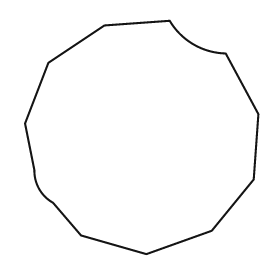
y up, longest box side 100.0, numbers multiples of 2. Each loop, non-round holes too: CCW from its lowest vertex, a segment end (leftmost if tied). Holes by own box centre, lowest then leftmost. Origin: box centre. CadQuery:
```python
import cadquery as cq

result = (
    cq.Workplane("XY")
    .moveTo(2.0, -50.0)
    .lineTo(30.0, -40.0)
    .lineTo(48.0, -18.0)
    .lineTo(50.0, 10.0)
    .lineTo(36.0, 36.0)
    .threePointArc((22.0, 40.0), (12.0, 50.0))
    .lineTo(-16.0, 48.0)
    .lineTo(-40.0, 32.0)
    .lineTo(-50.0, 6.0)
    .lineTo(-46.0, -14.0)
    .threePointArc((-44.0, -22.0), (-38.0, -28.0))
    .lineTo(-26.0, -42.0)
    .close()
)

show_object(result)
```